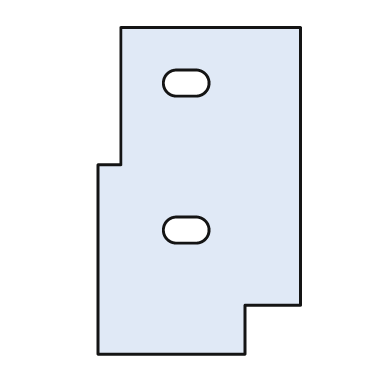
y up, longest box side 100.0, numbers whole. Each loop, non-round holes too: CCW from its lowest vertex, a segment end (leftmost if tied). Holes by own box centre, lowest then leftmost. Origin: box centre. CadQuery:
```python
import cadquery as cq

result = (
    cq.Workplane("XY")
    .moveTo(-31.0, -50.0)
    .lineTo(14.0, -50.0)
    .lineTo(14.0, -35.0)
    .lineTo(31.0, -35.0)
    .lineTo(31.0, 50.0)
    .lineTo(-24.0, 50.0)
    .lineTo(-24.0, 8.0)
    .lineTo(-31.0, 8.0)
    .close()
    .moveTo(-7.0, -16.0)
    .lineTo(-1.0, -16.0)
    .threePointArc((3.0, -12.0), (-1.0, -8.0))
    .lineTo(-7.0, -8.0)
    .threePointArc((-11.0, -12.0), (-7.0, -16.0))
    .close()
    .moveTo(-7.0, 29.0)
    .lineTo(-1.0, 29.0)
    .threePointArc((3.0, 33.0), (-1.0, 37.0))
    .lineTo(-7.0, 37.0)
    .threePointArc((-11.0, 33.0), (-7.0, 29.0))
    .close()
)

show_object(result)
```